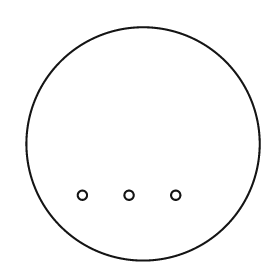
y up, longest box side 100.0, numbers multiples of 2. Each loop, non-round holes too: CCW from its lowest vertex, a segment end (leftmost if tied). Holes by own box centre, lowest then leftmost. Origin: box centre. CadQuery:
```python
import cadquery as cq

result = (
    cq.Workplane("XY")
    .moveTo(0.0, 0.0)
    .circle(50.0)
    .moveTo(-26.0, -22.0)
    .circle(2.0)
    .moveTo(-6.0, -22.0)
    .circle(2.0)
    .moveTo(14.0, -22.0)
    .circle(2.0)
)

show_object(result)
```